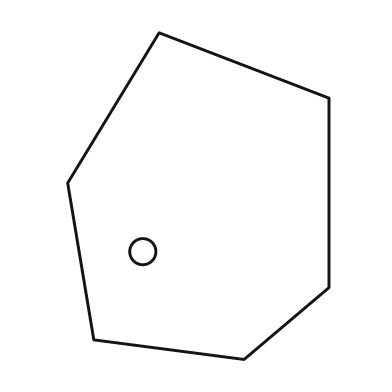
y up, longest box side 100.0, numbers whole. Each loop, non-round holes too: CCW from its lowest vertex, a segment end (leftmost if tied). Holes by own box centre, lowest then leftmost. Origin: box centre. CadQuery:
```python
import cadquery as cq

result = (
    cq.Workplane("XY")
    .moveTo(14.0, -50.0)
    .lineTo(40.0, -28.0)
    .lineTo(40.0, 30.0)
    .lineTo(-12.0, 50.0)
    .lineTo(-40.0, 4.0)
    .lineTo(-32.0, -44.0)
    .close()
    .moveTo(-17.0, -17.0)
    .circle(4.0)
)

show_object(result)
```